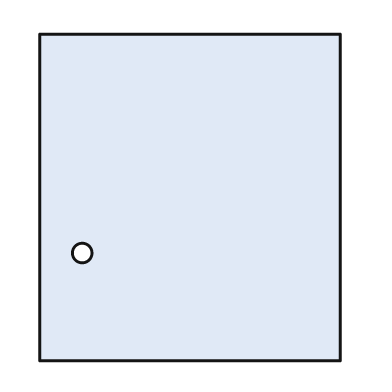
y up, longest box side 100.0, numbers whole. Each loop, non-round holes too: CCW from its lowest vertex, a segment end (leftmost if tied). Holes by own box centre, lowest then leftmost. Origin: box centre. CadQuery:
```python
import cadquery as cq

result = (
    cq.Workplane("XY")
    .moveTo(-46.0, -50.0)
    .lineTo(46.0, -50.0)
    .lineTo(46.0, 50.0)
    .lineTo(-46.0, 50.0)
    .close()
    .moveTo(-33.0, -17.0)
    .circle(3.0)
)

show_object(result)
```